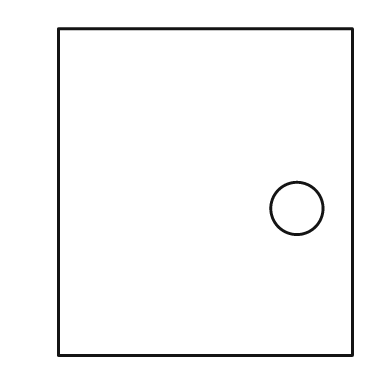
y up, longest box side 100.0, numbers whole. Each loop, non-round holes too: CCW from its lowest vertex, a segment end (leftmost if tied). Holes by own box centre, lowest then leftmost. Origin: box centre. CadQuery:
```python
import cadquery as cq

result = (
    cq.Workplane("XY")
    .moveTo(-45.0, -50.0)
    .lineTo(45.0, -50.0)
    .lineTo(45.0, 50.0)
    .lineTo(-45.0, 50.0)
    .close()
    .moveTo(28.0, -5.0)
    .circle(8.0)
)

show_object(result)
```